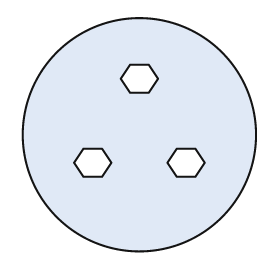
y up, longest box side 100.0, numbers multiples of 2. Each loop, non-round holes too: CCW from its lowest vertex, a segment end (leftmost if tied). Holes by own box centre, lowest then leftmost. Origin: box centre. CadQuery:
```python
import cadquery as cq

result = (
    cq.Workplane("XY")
    .moveTo(0.0, 0.0)
    .circle(50.0)
    .moveTo(-24.0, -18.0)
    .lineTo(-16.0, -18.0)
    .lineTo(-12.0, -12.0)
    .lineTo(-16.0, -6.0)
    .lineTo(-24.0, -6.0)
    .lineTo(-28.0, -12.0)
    .close()
    .moveTo(16.0, -18.0)
    .lineTo(24.0, -18.0)
    .lineTo(28.0, -12.0)
    .lineTo(24.0, -6.0)
    .lineTo(16.0, -6.0)
    .lineTo(12.0, -12.0)
    .close()
    .moveTo(-4.0, 18.0)
    .lineTo(4.0, 18.0)
    .lineTo(8.0, 24.0)
    .lineTo(4.0, 30.0)
    .lineTo(-4.0, 30.0)
    .lineTo(-8.0, 24.0)
    .close()
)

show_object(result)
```